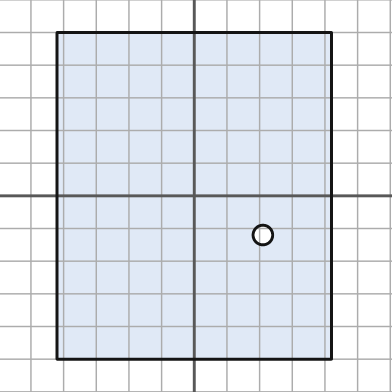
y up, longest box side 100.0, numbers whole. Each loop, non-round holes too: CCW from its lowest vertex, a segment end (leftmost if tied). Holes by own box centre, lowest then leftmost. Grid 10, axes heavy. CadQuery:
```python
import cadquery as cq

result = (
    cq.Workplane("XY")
    .moveTo(-42.0, -50.0)
    .lineTo(42.0, -50.0)
    .lineTo(42.0, 50.0)
    .lineTo(-42.0, 50.0)
    .close()
    .moveTo(21.0, -12.0)
    .circle(3.0)
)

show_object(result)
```